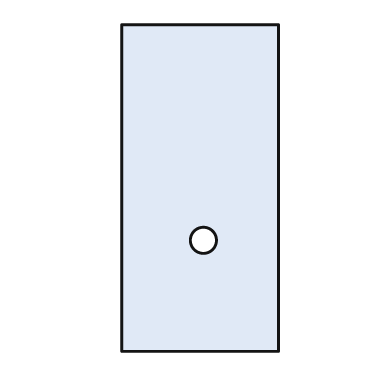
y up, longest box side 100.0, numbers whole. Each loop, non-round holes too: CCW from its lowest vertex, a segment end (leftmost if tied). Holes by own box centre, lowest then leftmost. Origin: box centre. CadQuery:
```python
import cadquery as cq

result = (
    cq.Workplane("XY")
    .moveTo(-24.0, -50.0)
    .lineTo(24.0, -50.0)
    .lineTo(24.0, 50.0)
    .lineTo(-24.0, 50.0)
    .close()
    .moveTo(1.0, -16.0)
    .circle(4.0)
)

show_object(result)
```